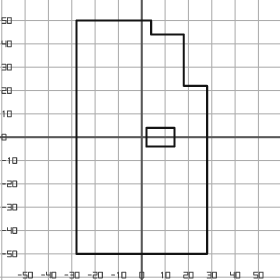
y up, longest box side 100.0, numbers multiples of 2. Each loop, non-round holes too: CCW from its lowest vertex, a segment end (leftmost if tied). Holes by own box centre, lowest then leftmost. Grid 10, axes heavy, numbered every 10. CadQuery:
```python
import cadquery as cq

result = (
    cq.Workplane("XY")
    .moveTo(-28.0, -50.0)
    .lineTo(28.0, -50.0)
    .lineTo(28.0, 22.0)
    .lineTo(18.0, 22.0)
    .lineTo(18.0, 44.0)
    .lineTo(4.0, 44.0)
    .lineTo(4.0, 50.0)
    .lineTo(-28.0, 50.0)
    .close()
    .moveTo(2.0, -4.0)
    .lineTo(14.0, -4.0)
    .lineTo(14.0, 4.0)
    .lineTo(2.0, 4.0)
    .close()
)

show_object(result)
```